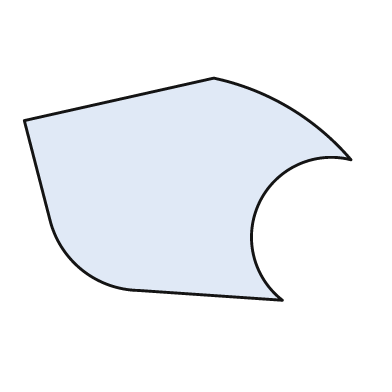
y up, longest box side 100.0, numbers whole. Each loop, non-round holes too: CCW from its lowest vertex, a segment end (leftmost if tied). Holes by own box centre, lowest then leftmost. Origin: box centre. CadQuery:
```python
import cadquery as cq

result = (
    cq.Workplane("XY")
    .moveTo(29.0, -34.0)
    .threePointArc((22.0, -4.0), (50.0, 9.0))
    .threePointArc((31.0, 25.0), (8.0, 34.0))
    .lineTo(-50.0, 21.0)
    .lineTo(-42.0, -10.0)
    .threePointArc((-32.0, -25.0), (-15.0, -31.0))
    .close()
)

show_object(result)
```